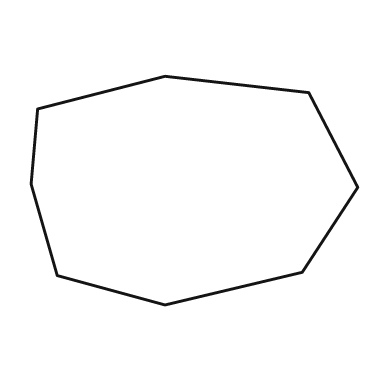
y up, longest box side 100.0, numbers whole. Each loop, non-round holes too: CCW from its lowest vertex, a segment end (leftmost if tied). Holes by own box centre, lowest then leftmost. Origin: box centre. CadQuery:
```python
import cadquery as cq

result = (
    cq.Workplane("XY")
    .moveTo(-9.0, -35.0)
    .lineTo(33.0, -25.0)
    .lineTo(50.0, 1.0)
    .lineTo(35.0, 30.0)
    .lineTo(-9.0, 35.0)
    .lineTo(-48.0, 25.0)
    .lineTo(-50.0, 2.0)
    .lineTo(-42.0, -26.0)
    .close()
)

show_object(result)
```